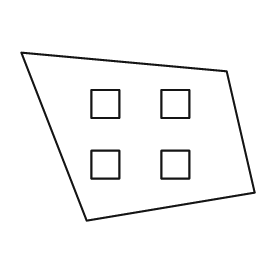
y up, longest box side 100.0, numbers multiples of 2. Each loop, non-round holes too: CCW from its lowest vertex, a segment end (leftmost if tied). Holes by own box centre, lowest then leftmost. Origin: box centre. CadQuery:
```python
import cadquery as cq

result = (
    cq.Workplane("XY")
    .moveTo(-22.0, -36.0)
    .lineTo(50.0, -24.0)
    .lineTo(38.0, 28.0)
    .lineTo(-50.0, 36.0)
    .close()
    .moveTo(-20.0, -18.0)
    .lineTo(-8.0, -18.0)
    .lineTo(-8.0, -6.0)
    .lineTo(-20.0, -6.0)
    .close()
    .moveTo(10.0, -18.0)
    .lineTo(22.0, -18.0)
    .lineTo(22.0, -6.0)
    .lineTo(10.0, -6.0)
    .close()
    .moveTo(-20.0, 8.0)
    .lineTo(-8.0, 8.0)
    .lineTo(-8.0, 20.0)
    .lineTo(-20.0, 20.0)
    .close()
    .moveTo(10.0, 8.0)
    .lineTo(22.0, 8.0)
    .lineTo(22.0, 20.0)
    .lineTo(10.0, 20.0)
    .close()
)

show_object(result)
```